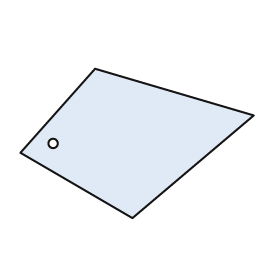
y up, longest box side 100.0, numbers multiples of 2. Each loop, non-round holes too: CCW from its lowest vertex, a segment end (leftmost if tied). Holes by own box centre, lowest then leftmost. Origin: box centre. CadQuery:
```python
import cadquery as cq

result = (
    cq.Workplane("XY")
    .moveTo(-2.0, -32.0)
    .lineTo(50.0, 12.0)
    .lineTo(-18.0, 32.0)
    .lineTo(-50.0, -4.0)
    .close()
    .moveTo(-36.0, 0.0)
    .circle(2.0)
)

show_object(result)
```